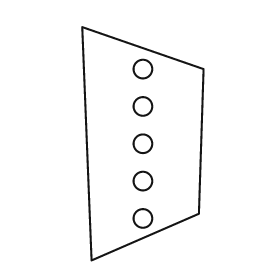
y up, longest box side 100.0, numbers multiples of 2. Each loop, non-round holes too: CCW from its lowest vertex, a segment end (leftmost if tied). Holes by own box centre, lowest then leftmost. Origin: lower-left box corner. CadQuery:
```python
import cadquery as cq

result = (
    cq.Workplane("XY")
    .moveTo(4.0, 0.0)
    .lineTo(50.0, 20.0)
    .lineTo(52.0, 82.0)
    .lineTo(0.0, 100.0)
    .close()
    .moveTo(26.0, 18.0)
    .circle(4.0)
    .moveTo(26.0, 34.0)
    .circle(4.0)
    .moveTo(26.0, 50.0)
    .circle(4.0)
    .moveTo(26.0, 66.0)
    .circle(4.0)
    .moveTo(26.0, 82.0)
    .circle(4.0)
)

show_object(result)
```